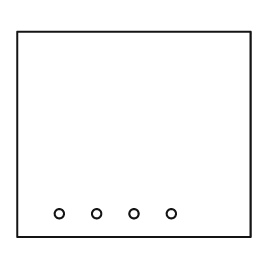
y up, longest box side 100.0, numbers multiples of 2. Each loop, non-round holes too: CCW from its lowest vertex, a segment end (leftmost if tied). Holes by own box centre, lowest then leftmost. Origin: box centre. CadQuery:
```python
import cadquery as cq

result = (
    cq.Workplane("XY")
    .moveTo(-50.0, -44.0)
    .lineTo(50.0, -44.0)
    .lineTo(50.0, 44.0)
    .lineTo(-50.0, 44.0)
    .close()
    .moveTo(-32.0, -34.0)
    .circle(2.0)
    .moveTo(-16.0, -34.0)
    .circle(2.0)
    .moveTo(0.0, -34.0)
    .circle(2.0)
    .moveTo(16.0, -34.0)
    .circle(2.0)
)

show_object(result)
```